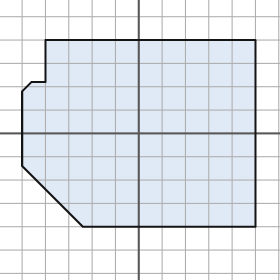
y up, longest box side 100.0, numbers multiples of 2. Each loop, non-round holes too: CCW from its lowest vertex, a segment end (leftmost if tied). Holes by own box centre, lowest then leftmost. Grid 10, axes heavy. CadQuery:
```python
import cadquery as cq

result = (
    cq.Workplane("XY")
    .moveTo(-24.0, -40.0)
    .lineTo(50.0, -40.0)
    .lineTo(50.0, 40.0)
    .lineTo(-40.0, 40.0)
    .lineTo(-40.0, 22.0)
    .lineTo(-46.0, 22.0)
    .lineTo(-50.0, 18.0)
    .lineTo(-50.0, -14.0)
    .close()
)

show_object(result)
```